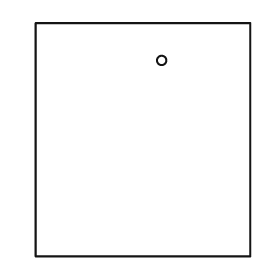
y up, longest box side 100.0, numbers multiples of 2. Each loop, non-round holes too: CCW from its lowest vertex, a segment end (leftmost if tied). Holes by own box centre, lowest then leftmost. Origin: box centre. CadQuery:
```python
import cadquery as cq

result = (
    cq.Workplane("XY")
    .moveTo(-46.0, -50.0)
    .lineTo(46.0, -50.0)
    .lineTo(46.0, 50.0)
    .lineTo(-46.0, 50.0)
    .close()
    .moveTo(8.0, 34.0)
    .circle(2.0)
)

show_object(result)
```